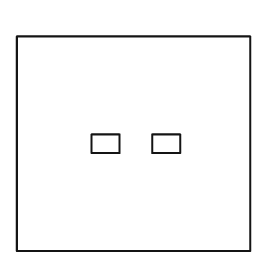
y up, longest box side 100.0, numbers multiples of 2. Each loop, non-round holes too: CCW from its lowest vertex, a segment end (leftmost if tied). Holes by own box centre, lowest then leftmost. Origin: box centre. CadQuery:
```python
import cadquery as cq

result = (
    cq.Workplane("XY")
    .moveTo(-50.0, -46.0)
    .lineTo(50.0, -46.0)
    .lineTo(50.0, 46.0)
    .lineTo(-50.0, 46.0)
    .close()
    .moveTo(-18.0, -4.0)
    .lineTo(-6.0, -4.0)
    .lineTo(-6.0, 4.0)
    .lineTo(-18.0, 4.0)
    .close()
    .moveTo(8.0, -4.0)
    .lineTo(20.0, -4.0)
    .lineTo(20.0, 4.0)
    .lineTo(8.0, 4.0)
    .close()
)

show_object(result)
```